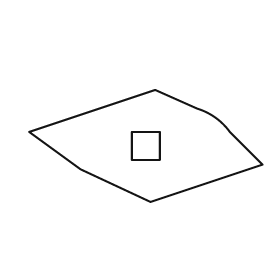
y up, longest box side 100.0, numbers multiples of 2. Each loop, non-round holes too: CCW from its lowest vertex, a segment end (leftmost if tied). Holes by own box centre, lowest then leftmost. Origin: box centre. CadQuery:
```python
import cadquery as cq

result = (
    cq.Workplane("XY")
    .moveTo(2.0, -24.0)
    .lineTo(50.0, -8.0)
    .lineTo(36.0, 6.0)
    .threePointArc((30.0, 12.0), (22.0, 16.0))
    .lineTo(4.0, 24.0)
    .lineTo(-50.0, 6.0)
    .lineTo(-28.0, -10.0)
    .close()
    .moveTo(-6.0, -6.0)
    .lineTo(6.0, -6.0)
    .lineTo(6.0, 6.0)
    .lineTo(-6.0, 6.0)
    .close()
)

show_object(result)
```